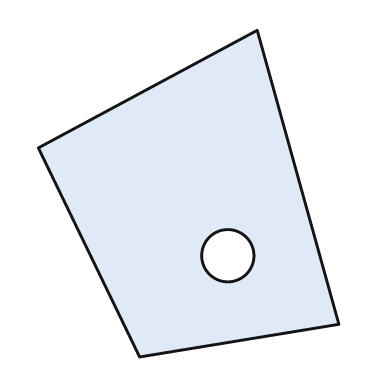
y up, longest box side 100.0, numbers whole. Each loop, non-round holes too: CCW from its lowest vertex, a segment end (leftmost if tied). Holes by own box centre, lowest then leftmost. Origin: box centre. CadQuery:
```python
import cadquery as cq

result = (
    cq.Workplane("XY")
    .moveTo(-15.0, -50.0)
    .lineTo(46.0, -40.0)
    .lineTo(21.0, 50.0)
    .lineTo(-46.0, 14.0)
    .close()
    .moveTo(12.0, -19.0)
    .circle(8.0)
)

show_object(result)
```